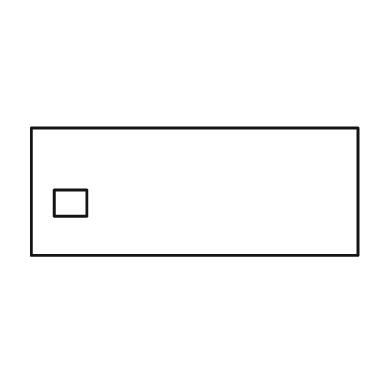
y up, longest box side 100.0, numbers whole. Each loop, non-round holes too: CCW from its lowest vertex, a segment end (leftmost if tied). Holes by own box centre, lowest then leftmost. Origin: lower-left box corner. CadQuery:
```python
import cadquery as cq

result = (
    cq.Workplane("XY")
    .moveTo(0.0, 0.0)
    .lineTo(100.0, 0.0)
    .lineTo(100.0, 39.0)
    .lineTo(0.0, 39.0)
    .close()
    .moveTo(7.0, 12.0)
    .lineTo(17.0, 12.0)
    .lineTo(17.0, 20.0)
    .lineTo(7.0, 20.0)
    .close()
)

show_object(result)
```